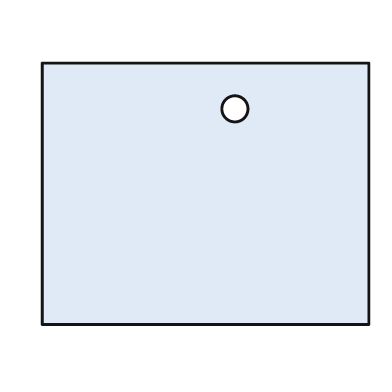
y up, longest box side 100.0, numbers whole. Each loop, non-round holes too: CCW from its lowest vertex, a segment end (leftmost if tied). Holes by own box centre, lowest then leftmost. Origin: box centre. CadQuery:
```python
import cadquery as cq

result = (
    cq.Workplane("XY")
    .moveTo(-50.0, -40.0)
    .lineTo(50.0, -40.0)
    .lineTo(50.0, 40.0)
    .lineTo(-50.0, 40.0)
    .close()
    .moveTo(9.0, 26.0)
    .circle(4.0)
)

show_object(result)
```